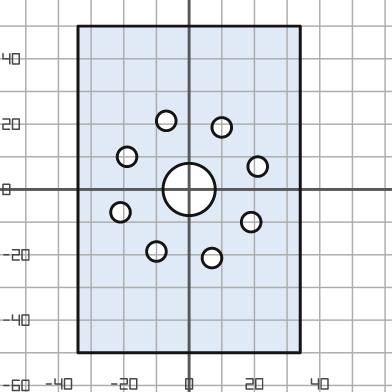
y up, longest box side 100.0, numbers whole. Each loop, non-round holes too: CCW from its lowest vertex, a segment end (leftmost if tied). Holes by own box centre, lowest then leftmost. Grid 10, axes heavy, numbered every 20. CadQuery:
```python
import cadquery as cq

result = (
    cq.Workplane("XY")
    .moveTo(-34.0, -50.0)
    .lineTo(34.0, -50.0)
    .lineTo(34.0, 50.0)
    .lineTo(-34.0, 50.0)
    .close()
    .moveTo(7.0, -21.0)
    .circle(3.0)
    .moveTo(-10.0, -19.0)
    .circle(3.0)
    .moveTo(19.0, -10.0)
    .circle(3.0)
    .moveTo(-21.0, -7.0)
    .circle(3.0)
    .moveTo(0.0, 0.0)
    .circle(8.0)
    .moveTo(21.0, 7.0)
    .circle(3.0)
    .moveTo(-19.0, 10.0)
    .circle(3.0)
    .moveTo(10.0, 19.0)
    .circle(3.0)
    .moveTo(-7.0, 21.0)
    .circle(3.0)
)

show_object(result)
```